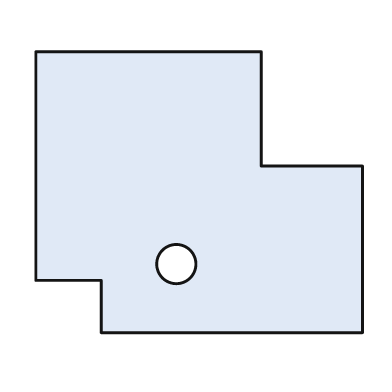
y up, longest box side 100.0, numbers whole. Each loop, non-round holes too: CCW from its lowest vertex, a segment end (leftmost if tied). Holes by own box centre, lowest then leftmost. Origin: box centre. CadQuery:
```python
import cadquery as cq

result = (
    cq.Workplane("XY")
    .moveTo(-30.0, -43.0)
    .lineTo(50.0, -43.0)
    .lineTo(50.0, 8.0)
    .lineTo(19.0, 8.0)
    .lineTo(19.0, 43.0)
    .lineTo(-50.0, 43.0)
    .lineTo(-50.0, -27.0)
    .lineTo(-30.0, -27.0)
    .close()
    .moveTo(-7.0, -22.0)
    .circle(6.0)
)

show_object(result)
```